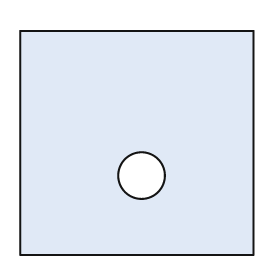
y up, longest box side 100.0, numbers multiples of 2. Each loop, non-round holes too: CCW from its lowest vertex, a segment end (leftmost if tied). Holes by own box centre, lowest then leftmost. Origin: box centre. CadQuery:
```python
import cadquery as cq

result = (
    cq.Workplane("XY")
    .moveTo(-50.0, -48.0)
    .lineTo(50.0, -48.0)
    .lineTo(50.0, 48.0)
    .lineTo(-50.0, 48.0)
    .close()
    .moveTo(2.0, -14.0)
    .circle(10.0)
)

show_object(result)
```